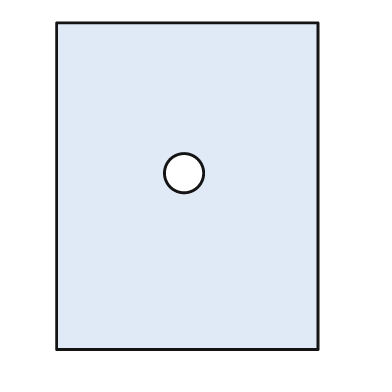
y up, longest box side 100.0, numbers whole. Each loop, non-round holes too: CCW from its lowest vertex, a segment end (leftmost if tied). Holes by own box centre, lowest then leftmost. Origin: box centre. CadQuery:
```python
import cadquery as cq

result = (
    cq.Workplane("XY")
    .moveTo(-40.0, -50.0)
    .lineTo(40.0, -50.0)
    .lineTo(40.0, 50.0)
    .lineTo(-40.0, 50.0)
    .close()
    .moveTo(-1.0, 4.0)
    .circle(6.0)
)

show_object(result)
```